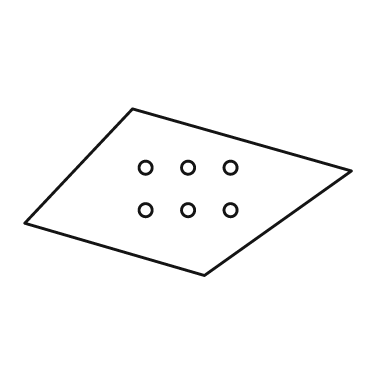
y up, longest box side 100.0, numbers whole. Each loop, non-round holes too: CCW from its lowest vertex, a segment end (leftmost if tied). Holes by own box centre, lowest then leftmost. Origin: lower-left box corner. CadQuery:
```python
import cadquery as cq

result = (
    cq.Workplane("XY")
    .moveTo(55.0, 0.0)
    .lineTo(100.0, 32.0)
    .lineTo(33.0, 51.0)
    .lineTo(0.0, 16.0)
    .close()
    .moveTo(37.0, 20.0)
    .circle(2.0)
    .moveTo(50.0, 20.0)
    .circle(2.0)
    .moveTo(63.0, 20.0)
    .circle(2.0)
    .moveTo(37.0, 33.0)
    .circle(2.0)
    .moveTo(50.0, 33.0)
    .circle(2.0)
    .moveTo(63.0, 33.0)
    .circle(2.0)
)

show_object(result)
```